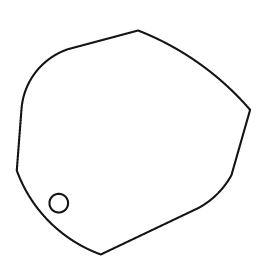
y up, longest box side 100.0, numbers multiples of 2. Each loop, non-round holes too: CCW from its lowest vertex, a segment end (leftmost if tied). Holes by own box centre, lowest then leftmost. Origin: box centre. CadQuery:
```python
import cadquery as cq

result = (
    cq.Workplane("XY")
    .moveTo(-14.0, -48.0)
    .lineTo(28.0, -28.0)
    .threePointArc((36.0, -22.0), (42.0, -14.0))
    .lineTo(50.0, 14.0)
    .threePointArc((28.0, 34.0), (2.0, 48.0))
    .lineTo(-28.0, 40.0)
    .threePointArc((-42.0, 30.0), (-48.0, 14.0))
    .lineTo(-50.0, -12.0)
    .threePointArc((-36.0, -34.0), (-14.0, -48.0))
    .close()
    .moveTo(-32.0, -26.0)
    .circle(4.0)
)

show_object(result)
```